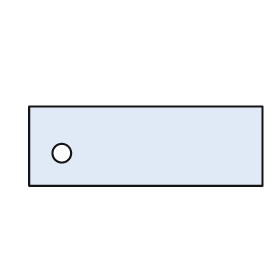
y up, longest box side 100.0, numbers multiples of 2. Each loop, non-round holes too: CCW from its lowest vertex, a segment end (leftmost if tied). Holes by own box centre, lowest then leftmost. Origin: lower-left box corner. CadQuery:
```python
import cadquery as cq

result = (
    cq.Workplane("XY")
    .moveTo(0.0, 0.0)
    .lineTo(100.0, 0.0)
    .lineTo(100.0, 34.0)
    .lineTo(0.0, 34.0)
    .close()
    .moveTo(14.0, 14.0)
    .circle(4.0)
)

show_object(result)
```